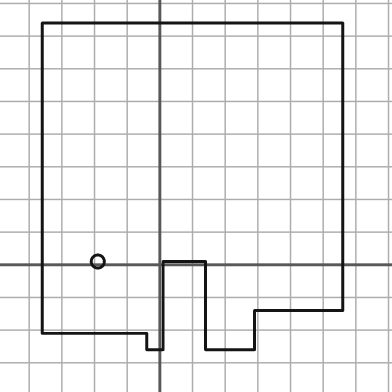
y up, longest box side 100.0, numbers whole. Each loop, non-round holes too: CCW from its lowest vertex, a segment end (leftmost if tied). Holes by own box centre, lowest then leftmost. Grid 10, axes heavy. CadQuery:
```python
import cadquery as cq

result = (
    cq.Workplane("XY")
    .moveTo(-4.0, -26.0)
    .lineTo(1.0, -26.0)
    .lineTo(1.0, 1.0)
    .lineTo(14.0, 1.0)
    .lineTo(14.0, -26.0)
    .lineTo(29.0, -26.0)
    .lineTo(29.0, -14.0)
    .lineTo(56.0, -14.0)
    .lineTo(56.0, 74.0)
    .lineTo(-36.0, 74.0)
    .lineTo(-36.0, -21.0)
    .lineTo(-4.0, -21.0)
    .close()
    .moveTo(-19.0, 1.0)
    .circle(2.0)
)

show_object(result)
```